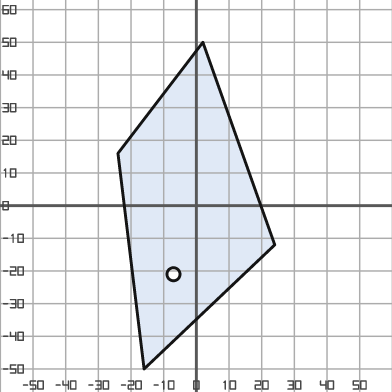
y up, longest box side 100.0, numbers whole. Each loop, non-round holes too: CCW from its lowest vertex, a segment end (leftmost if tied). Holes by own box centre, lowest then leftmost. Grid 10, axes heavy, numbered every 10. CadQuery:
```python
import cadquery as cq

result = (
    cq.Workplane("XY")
    .moveTo(-16.0, -50.0)
    .lineTo(24.0, -12.0)
    .lineTo(2.0, 50.0)
    .lineTo(-24.0, 16.0)
    .close()
    .moveTo(-7.0, -21.0)
    .circle(2.0)
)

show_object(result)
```